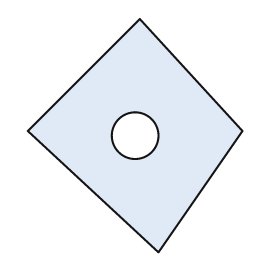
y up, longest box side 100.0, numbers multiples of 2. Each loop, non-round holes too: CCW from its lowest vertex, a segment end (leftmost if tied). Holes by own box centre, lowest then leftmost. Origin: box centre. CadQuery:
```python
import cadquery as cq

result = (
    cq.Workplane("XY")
    .moveTo(10.0, -50.0)
    .lineTo(46.0, 2.0)
    .lineTo(2.0, 50.0)
    .lineTo(-46.0, 2.0)
    .close()
    .moveTo(0.0, 0.0)
    .circle(10.0)
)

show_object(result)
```